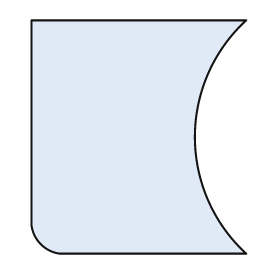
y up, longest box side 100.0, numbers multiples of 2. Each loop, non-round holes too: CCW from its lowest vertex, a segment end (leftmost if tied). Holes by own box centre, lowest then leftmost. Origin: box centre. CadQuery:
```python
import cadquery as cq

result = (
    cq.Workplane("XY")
    .moveTo(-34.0, -50.0)
    .lineTo(46.0, -50.0)
    .threePointArc((24.0, 0.0), (46.0, 50.0))
    .lineTo(-46.0, 50.0)
    .lineTo(-46.0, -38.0)
    .threePointArc((-42.0, -46.0), (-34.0, -50.0))
    .close()
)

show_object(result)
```